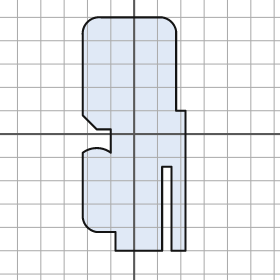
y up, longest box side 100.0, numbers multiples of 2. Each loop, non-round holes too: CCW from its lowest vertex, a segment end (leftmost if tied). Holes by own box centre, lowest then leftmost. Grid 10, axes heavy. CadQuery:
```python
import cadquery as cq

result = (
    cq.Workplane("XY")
    .moveTo(-8.0, -50.0)
    .lineTo(12.0, -50.0)
    .lineTo(12.0, -14.0)
    .lineTo(16.0, -14.0)
    .lineTo(16.0, -50.0)
    .lineTo(22.0, -50.0)
    .lineTo(22.0, 10.0)
    .lineTo(18.0, 10.0)
    .lineTo(18.0, 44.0)
    .threePointArc((16.0, 48.0), (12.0, 50.0))
    .lineTo(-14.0, 50.0)
    .threePointArc((-20.0, 48.0), (-22.0, 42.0))
    .lineTo(-22.0, 8.0)
    .lineTo(-16.0, 2.0)
    .lineTo(-10.0, 2.0)
    .lineTo(-10.0, -8.0)
    .threePointArc((-16.0, -6.0), (-22.0, -8.0))
    .lineTo(-22.0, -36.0)
    .threePointArc((-20.0, -40.0), (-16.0, -42.0))
    .lineTo(-8.0, -42.0)
    .close()
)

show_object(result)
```